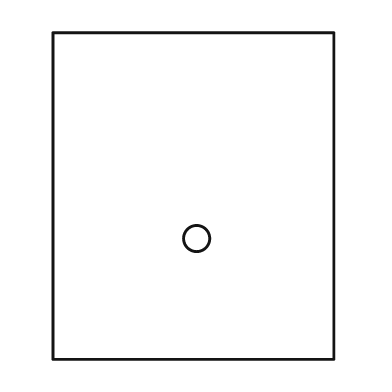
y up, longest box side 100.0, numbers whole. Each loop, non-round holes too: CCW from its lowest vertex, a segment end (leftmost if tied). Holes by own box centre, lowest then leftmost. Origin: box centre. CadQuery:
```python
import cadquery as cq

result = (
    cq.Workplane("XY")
    .moveTo(-43.0, -50.0)
    .lineTo(43.0, -50.0)
    .lineTo(43.0, 50.0)
    .lineTo(-43.0, 50.0)
    .close()
    .moveTo(1.0, -13.0)
    .circle(4.0)
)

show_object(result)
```